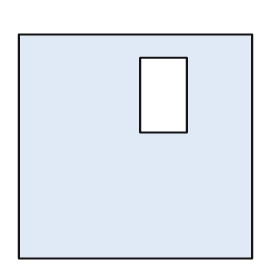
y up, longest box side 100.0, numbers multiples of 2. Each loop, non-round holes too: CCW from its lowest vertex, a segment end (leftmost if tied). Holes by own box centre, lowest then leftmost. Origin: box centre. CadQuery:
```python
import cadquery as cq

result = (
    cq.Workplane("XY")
    .moveTo(-50.0, -48.0)
    .lineTo(50.0, -48.0)
    .lineTo(50.0, 48.0)
    .lineTo(-50.0, 48.0)
    .close()
    .moveTo(2.0, 6.0)
    .lineTo(22.0, 6.0)
    .lineTo(22.0, 38.0)
    .lineTo(2.0, 38.0)
    .close()
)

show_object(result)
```